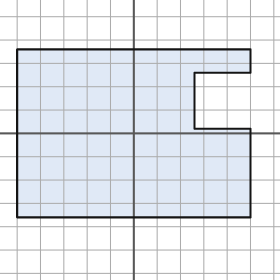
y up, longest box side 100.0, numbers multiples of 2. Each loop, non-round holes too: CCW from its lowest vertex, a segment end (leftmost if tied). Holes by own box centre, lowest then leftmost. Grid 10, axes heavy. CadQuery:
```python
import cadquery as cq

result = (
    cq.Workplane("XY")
    .moveTo(-50.0, -36.0)
    .lineTo(50.0, -36.0)
    .lineTo(50.0, 2.0)
    .lineTo(26.0, 2.0)
    .lineTo(26.0, 26.0)
    .lineTo(50.0, 26.0)
    .lineTo(50.0, 36.0)
    .lineTo(-50.0, 36.0)
    .close()
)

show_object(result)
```